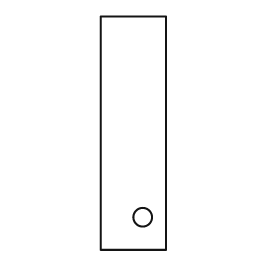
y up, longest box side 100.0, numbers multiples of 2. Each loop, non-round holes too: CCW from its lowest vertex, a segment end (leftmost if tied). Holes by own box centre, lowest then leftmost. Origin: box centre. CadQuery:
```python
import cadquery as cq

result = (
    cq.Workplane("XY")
    .moveTo(-14.0, -50.0)
    .lineTo(14.0, -50.0)
    .lineTo(14.0, 50.0)
    .lineTo(-14.0, 50.0)
    .close()
    .moveTo(4.0, -36.0)
    .circle(4.0)
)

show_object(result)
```